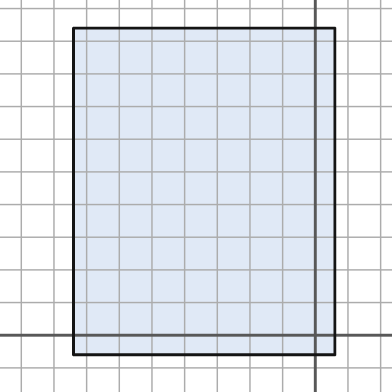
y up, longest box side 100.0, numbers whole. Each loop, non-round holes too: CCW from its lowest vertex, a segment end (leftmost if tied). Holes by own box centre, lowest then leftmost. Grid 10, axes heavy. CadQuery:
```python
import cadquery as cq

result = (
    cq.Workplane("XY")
    .moveTo(-74.0, -6.0)
    .lineTo(6.0, -6.0)
    .lineTo(6.0, 94.0)
    .lineTo(-74.0, 94.0)
    .close()
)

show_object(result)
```